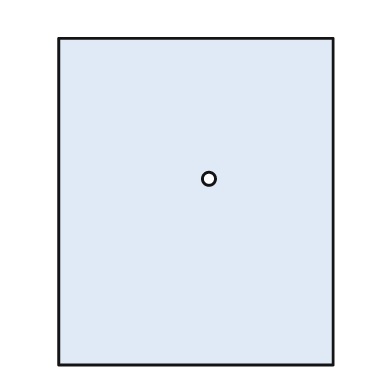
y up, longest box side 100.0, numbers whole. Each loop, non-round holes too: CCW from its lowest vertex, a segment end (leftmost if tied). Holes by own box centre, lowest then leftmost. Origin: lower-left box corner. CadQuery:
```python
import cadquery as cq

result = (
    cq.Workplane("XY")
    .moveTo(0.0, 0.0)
    .lineTo(84.0, 0.0)
    .lineTo(84.0, 100.0)
    .lineTo(0.0, 100.0)
    .close()
    .moveTo(46.0, 57.0)
    .circle(2.0)
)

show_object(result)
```